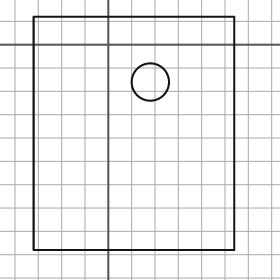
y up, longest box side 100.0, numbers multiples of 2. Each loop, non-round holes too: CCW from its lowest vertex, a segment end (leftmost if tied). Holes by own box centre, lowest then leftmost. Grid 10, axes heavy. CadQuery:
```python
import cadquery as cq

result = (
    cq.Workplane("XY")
    .moveTo(-32.0, -88.0)
    .lineTo(54.0, -88.0)
    .lineTo(54.0, 12.0)
    .lineTo(-32.0, 12.0)
    .close()
    .moveTo(18.0, -16.0)
    .circle(8.0)
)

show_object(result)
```